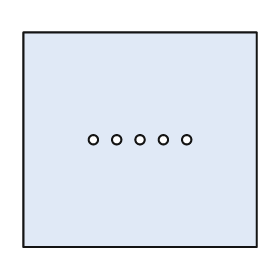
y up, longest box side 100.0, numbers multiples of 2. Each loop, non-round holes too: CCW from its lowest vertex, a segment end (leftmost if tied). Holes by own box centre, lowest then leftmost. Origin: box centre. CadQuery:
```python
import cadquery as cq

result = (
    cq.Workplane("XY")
    .moveTo(-50.0, -46.0)
    .lineTo(50.0, -46.0)
    .lineTo(50.0, 46.0)
    .lineTo(-50.0, 46.0)
    .close()
    .moveTo(-20.0, 0.0)
    .circle(2.0)
    .moveTo(-10.0, 0.0)
    .circle(2.0)
    .moveTo(0.0, 0.0)
    .circle(2.0)
    .moveTo(10.0, 0.0)
    .circle(2.0)
    .moveTo(20.0, 0.0)
    .circle(2.0)
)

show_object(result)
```